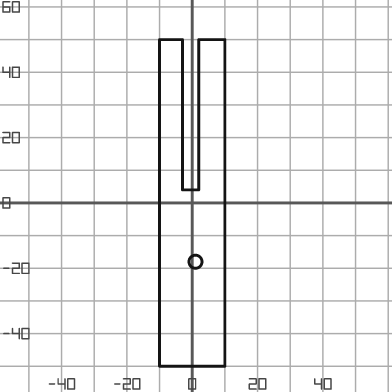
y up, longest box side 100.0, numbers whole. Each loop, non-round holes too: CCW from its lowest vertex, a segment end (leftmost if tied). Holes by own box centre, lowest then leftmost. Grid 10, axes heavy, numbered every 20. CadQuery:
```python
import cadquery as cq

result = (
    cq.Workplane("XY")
    .moveTo(-10.0, -50.0)
    .lineTo(10.0, -50.0)
    .lineTo(10.0, 50.0)
    .lineTo(2.0, 50.0)
    .lineTo(2.0, 4.0)
    .lineTo(-3.0, 4.0)
    .lineTo(-3.0, 50.0)
    .lineTo(-10.0, 50.0)
    .close()
    .moveTo(1.0, -18.0)
    .circle(2.0)
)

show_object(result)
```